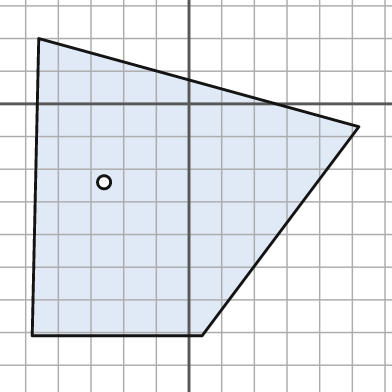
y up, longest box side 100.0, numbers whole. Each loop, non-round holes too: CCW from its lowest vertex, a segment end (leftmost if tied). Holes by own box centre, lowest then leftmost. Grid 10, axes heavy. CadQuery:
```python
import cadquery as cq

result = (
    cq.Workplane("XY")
    .moveTo(-48.0, -71.0)
    .lineTo(4.0, -71.0)
    .lineTo(52.0, -7.0)
    .lineTo(-46.0, 20.0)
    .close()
    .moveTo(-26.0, -24.0)
    .circle(2.0)
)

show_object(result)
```